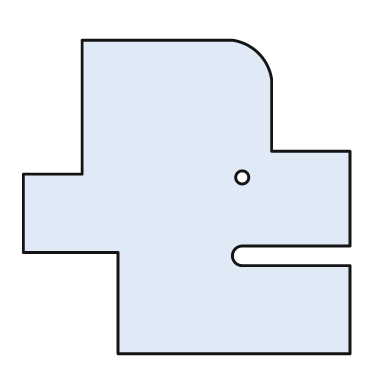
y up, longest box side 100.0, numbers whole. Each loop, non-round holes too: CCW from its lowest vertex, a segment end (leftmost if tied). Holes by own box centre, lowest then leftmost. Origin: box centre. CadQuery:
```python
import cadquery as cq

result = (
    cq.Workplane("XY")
    .moveTo(-21.0, -48.0)
    .lineTo(50.0, -48.0)
    .lineTo(50.0, -21.0)
    .lineTo(17.0, -21.0)
    .threePointArc((14.0, -18.0), (17.0, -15.0))
    .lineTo(50.0, -15.0)
    .lineTo(50.0, 14.0)
    .lineTo(26.0, 14.0)
    .lineTo(26.0, 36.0)
    .threePointArc((22.0, 44.0), (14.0, 48.0))
    .lineTo(-32.0, 48.0)
    .lineTo(-32.0, 7.0)
    .lineTo(-50.0, 7.0)
    .lineTo(-50.0, -17.0)
    .lineTo(-21.0, -17.0)
    .close()
    .moveTo(17.0, 6.0)
    .circle(2.0)
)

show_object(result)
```